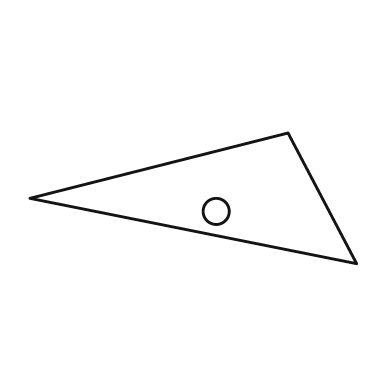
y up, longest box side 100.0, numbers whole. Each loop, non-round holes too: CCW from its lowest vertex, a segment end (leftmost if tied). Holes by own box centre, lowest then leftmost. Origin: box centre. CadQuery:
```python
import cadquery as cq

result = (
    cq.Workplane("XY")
    .moveTo(50.0, -20.0)
    .lineTo(29.0, 20.0)
    .lineTo(-50.0, 0.0)
    .close()
    .moveTo(7.0, -4.0)
    .circle(4.0)
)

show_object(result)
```